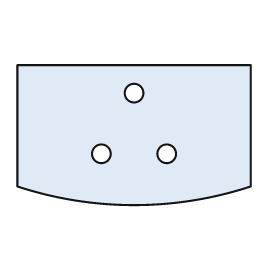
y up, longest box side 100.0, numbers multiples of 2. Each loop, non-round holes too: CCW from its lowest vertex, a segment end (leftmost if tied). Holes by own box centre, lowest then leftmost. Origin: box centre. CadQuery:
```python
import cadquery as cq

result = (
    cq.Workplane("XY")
    .moveTo(-50.0, -22.0)
    .threePointArc((0.0, -30.0), (50.0, -22.0))
    .lineTo(50.0, 30.0)
    .lineTo(-50.0, 30.0)
    .close()
    .moveTo(-14.0, -8.0)
    .circle(4.0)
    .moveTo(14.0, -8.0)
    .circle(4.0)
    .moveTo(0.0, 18.0)
    .circle(4.0)
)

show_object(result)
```